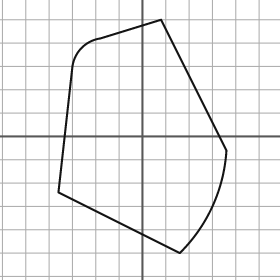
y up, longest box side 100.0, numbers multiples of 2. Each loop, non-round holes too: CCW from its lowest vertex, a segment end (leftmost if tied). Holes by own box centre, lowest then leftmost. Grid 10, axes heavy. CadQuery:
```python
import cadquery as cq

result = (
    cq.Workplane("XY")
    .moveTo(16.0, -50.0)
    .threePointArc((30.0, -30.0), (36.0, -6.0))
    .lineTo(8.0, 50.0)
    .lineTo(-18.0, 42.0)
    .threePointArc((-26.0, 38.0), (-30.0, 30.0))
    .lineTo(-36.0, -24.0)
    .close()
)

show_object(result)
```